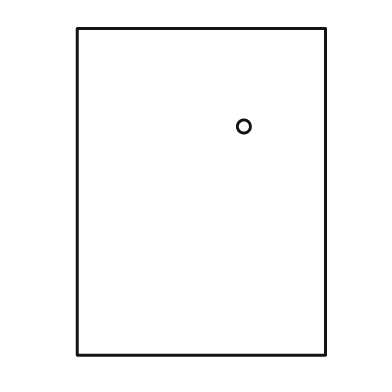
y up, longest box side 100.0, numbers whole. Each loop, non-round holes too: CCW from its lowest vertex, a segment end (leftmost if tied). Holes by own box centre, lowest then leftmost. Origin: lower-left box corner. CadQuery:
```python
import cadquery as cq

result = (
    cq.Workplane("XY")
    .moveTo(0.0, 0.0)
    .lineTo(76.0, 0.0)
    .lineTo(76.0, 100.0)
    .lineTo(0.0, 100.0)
    .close()
    .moveTo(51.0, 70.0)
    .circle(2.0)
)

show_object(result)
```